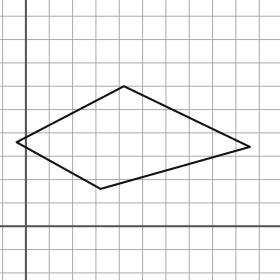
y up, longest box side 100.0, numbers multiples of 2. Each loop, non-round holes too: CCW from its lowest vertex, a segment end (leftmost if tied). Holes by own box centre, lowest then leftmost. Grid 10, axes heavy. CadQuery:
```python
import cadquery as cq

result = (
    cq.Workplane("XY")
    .moveTo(32.0, 16.0)
    .lineTo(96.0, 34.0)
    .lineTo(42.0, 60.0)
    .lineTo(-4.0, 36.0)
    .close()
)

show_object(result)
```